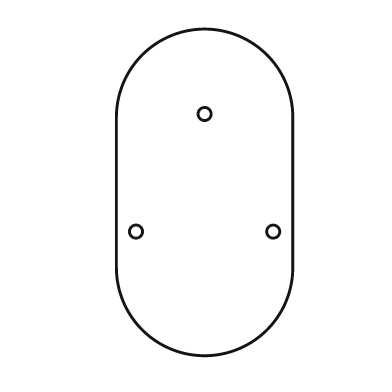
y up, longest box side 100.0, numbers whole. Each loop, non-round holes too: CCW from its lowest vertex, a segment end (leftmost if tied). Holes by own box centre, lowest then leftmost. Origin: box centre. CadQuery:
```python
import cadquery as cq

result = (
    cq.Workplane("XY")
    .moveTo(-27.0, -23.0)
    .threePointArc((0.0, -50.0), (27.0, -23.0))
    .lineTo(27.0, 23.0)
    .threePointArc((0.0, 50.0), (-27.0, 23.0))
    .close()
    .moveTo(-21.0, -12.0)
    .circle(2.0)
    .moveTo(21.0, -12.0)
    .circle(2.0)
    .moveTo(0.0, 24.0)
    .circle(2.0)
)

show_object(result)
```